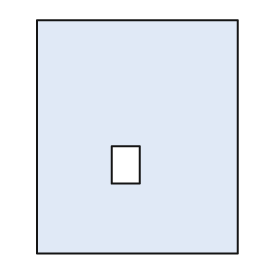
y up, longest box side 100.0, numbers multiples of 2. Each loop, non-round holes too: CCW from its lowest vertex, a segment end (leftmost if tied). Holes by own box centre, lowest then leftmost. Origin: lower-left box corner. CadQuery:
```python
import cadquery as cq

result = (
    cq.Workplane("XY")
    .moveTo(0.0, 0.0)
    .lineTo(86.0, 0.0)
    .lineTo(86.0, 100.0)
    .lineTo(0.0, 100.0)
    .close()
    .moveTo(32.0, 30.0)
    .lineTo(44.0, 30.0)
    .lineTo(44.0, 46.0)
    .lineTo(32.0, 46.0)
    .close()
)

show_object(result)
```